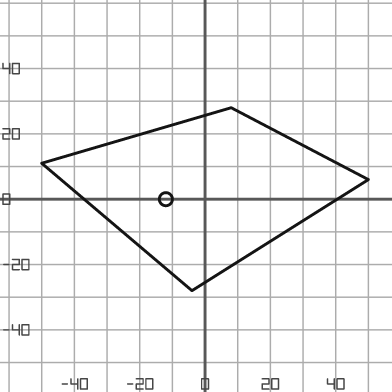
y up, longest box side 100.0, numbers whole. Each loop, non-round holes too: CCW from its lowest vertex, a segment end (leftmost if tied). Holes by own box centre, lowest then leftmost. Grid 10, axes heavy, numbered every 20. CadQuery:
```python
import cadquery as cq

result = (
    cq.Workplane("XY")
    .moveTo(-4.0, -28.0)
    .lineTo(50.0, 6.0)
    .lineTo(8.0, 28.0)
    .lineTo(-50.0, 11.0)
    .close()
    .moveTo(-12.0, 0.0)
    .circle(2.0)
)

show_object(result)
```